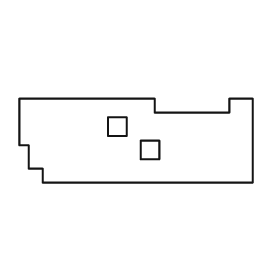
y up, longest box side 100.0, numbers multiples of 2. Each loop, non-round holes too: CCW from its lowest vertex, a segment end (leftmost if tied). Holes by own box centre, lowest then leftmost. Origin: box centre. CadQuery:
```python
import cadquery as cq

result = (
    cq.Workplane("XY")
    .moveTo(-40.0, -18.0)
    .lineTo(50.0, -18.0)
    .lineTo(50.0, 18.0)
    .lineTo(40.0, 18.0)
    .lineTo(40.0, 12.0)
    .lineTo(8.0, 12.0)
    .lineTo(8.0, 18.0)
    .lineTo(-50.0, 18.0)
    .lineTo(-50.0, -2.0)
    .lineTo(-46.0, -2.0)
    .lineTo(-46.0, -12.0)
    .lineTo(-40.0, -12.0)
    .close()
    .moveTo(2.0, -8.0)
    .lineTo(10.0, -8.0)
    .lineTo(10.0, 0.0)
    .lineTo(2.0, 0.0)
    .close()
    .moveTo(-12.0, 2.0)
    .lineTo(-4.0, 2.0)
    .lineTo(-4.0, 10.0)
    .lineTo(-12.0, 10.0)
    .close()
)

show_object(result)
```